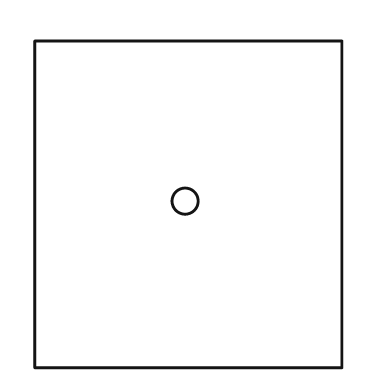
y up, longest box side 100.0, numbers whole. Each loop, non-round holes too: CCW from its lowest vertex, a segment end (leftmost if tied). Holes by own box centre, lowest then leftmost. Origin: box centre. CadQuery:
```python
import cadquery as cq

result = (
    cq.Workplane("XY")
    .moveTo(-47.0, -50.0)
    .lineTo(47.0, -50.0)
    .lineTo(47.0, 50.0)
    .lineTo(-47.0, 50.0)
    .close()
    .moveTo(-1.0, 1.0)
    .circle(4.0)
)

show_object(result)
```